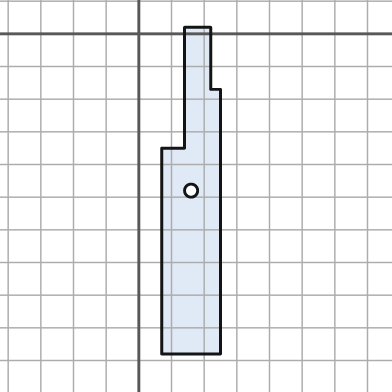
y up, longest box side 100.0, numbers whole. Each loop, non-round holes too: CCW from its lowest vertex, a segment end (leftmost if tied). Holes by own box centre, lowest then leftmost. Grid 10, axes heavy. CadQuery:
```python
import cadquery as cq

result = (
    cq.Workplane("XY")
    .moveTo(7.0, -98.0)
    .lineTo(25.0, -98.0)
    .lineTo(25.0, -17.0)
    .lineTo(22.0, -17.0)
    .lineTo(22.0, 2.0)
    .lineTo(14.0, 2.0)
    .lineTo(14.0, -35.0)
    .lineTo(7.0, -35.0)
    .close()
    .moveTo(16.0, -48.0)
    .circle(2.0)
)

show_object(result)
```